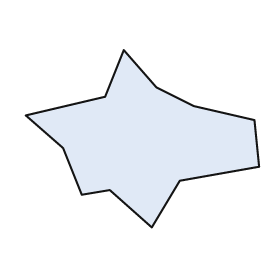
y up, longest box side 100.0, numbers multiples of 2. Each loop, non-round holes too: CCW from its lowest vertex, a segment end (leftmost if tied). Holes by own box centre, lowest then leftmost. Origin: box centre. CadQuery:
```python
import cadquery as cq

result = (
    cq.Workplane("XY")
    .moveTo(4.0, -38.0)
    .lineTo(16.0, -18.0)
    .lineTo(50.0, -12.0)
    .lineTo(48.0, 8.0)
    .lineTo(22.0, 14.0)
    .lineTo(6.0, 22.0)
    .lineTo(-8.0, 38.0)
    .lineTo(-16.0, 18.0)
    .lineTo(-50.0, 10.0)
    .lineTo(-34.0, -4.0)
    .lineTo(-26.0, -24.0)
    .lineTo(-14.0, -22.0)
    .close()
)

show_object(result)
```